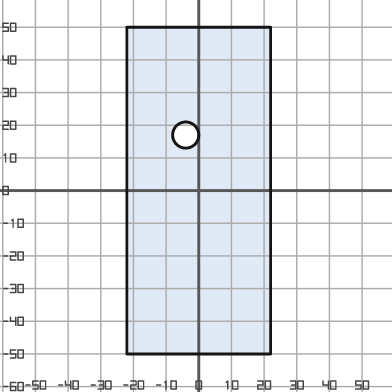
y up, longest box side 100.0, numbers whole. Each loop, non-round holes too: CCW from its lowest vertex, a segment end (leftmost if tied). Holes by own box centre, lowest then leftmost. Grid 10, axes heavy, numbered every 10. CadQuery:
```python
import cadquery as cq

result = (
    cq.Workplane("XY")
    .moveTo(-22.0, -50.0)
    .lineTo(22.0, -50.0)
    .lineTo(22.0, 50.0)
    .lineTo(-22.0, 50.0)
    .close()
    .moveTo(-4.0, 17.0)
    .circle(4.0)
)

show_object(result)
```